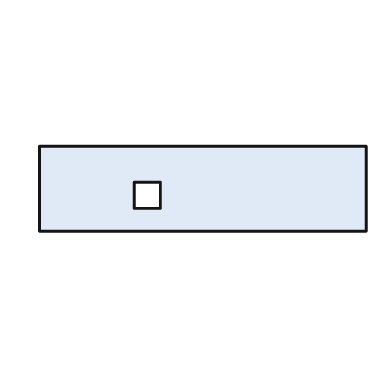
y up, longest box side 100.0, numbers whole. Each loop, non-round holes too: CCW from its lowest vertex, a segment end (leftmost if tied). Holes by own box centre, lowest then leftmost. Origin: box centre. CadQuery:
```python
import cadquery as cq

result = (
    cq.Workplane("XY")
    .moveTo(-50.0, -13.0)
    .lineTo(50.0, -13.0)
    .lineTo(50.0, 13.0)
    .lineTo(-50.0, 13.0)
    .close()
    .moveTo(-21.0, -6.0)
    .lineTo(-13.0, -6.0)
    .lineTo(-13.0, 2.0)
    .lineTo(-21.0, 2.0)
    .close()
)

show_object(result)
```